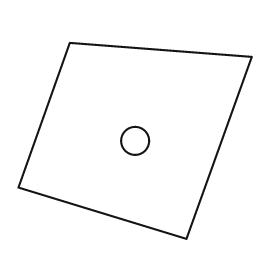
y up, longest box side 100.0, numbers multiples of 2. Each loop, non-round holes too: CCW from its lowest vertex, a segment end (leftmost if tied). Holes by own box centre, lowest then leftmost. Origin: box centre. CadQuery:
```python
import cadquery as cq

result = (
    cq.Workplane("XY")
    .moveTo(22.0, -42.0)
    .lineTo(50.0, 36.0)
    .lineTo(-28.0, 42.0)
    .lineTo(-50.0, -20.0)
    .close()
    .moveTo(0.0, 0.0)
    .circle(6.0)
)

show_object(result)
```